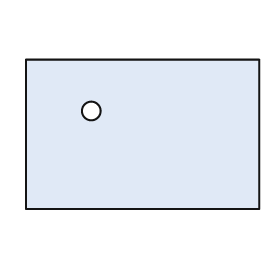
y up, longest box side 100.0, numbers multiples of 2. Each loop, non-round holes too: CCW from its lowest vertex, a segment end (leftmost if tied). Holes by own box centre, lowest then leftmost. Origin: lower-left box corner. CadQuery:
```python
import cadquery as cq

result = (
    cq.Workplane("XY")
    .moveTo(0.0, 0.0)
    .lineTo(100.0, 0.0)
    .lineTo(100.0, 64.0)
    .lineTo(0.0, 64.0)
    .close()
    .moveTo(28.0, 42.0)
    .circle(4.0)
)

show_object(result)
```